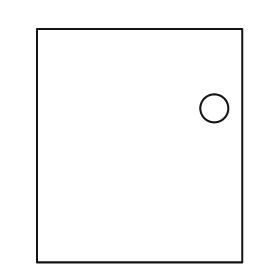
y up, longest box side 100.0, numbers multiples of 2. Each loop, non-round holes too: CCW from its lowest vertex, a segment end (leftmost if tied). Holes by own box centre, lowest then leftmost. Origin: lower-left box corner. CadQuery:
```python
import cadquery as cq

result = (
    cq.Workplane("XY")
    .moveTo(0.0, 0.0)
    .lineTo(88.0, 0.0)
    .lineTo(88.0, 100.0)
    .lineTo(0.0, 100.0)
    .close()
    .moveTo(76.0, 66.0)
    .circle(6.0)
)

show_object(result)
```